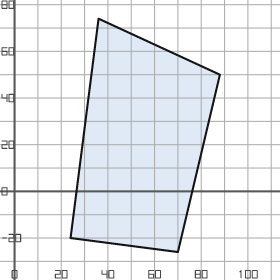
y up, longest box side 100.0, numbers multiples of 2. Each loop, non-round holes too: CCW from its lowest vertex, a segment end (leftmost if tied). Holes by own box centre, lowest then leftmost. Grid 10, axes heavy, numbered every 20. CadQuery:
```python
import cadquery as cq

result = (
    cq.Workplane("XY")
    .moveTo(70.0, -26.0)
    .lineTo(88.0, 50.0)
    .lineTo(36.0, 74.0)
    .lineTo(24.0, -20.0)
    .close()
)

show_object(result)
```